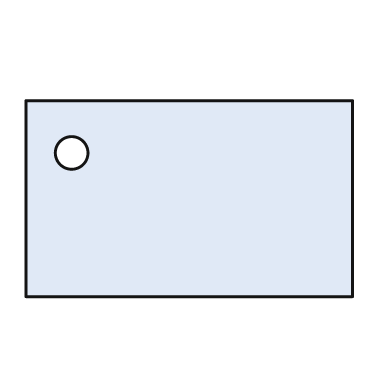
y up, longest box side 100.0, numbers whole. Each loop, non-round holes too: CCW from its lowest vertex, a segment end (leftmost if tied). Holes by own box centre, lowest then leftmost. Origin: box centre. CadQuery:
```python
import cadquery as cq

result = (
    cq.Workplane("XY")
    .moveTo(-50.0, -30.0)
    .lineTo(50.0, -30.0)
    .lineTo(50.0, 30.0)
    .lineTo(-50.0, 30.0)
    .close()
    .moveTo(-36.0, 14.0)
    .circle(5.0)
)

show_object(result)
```